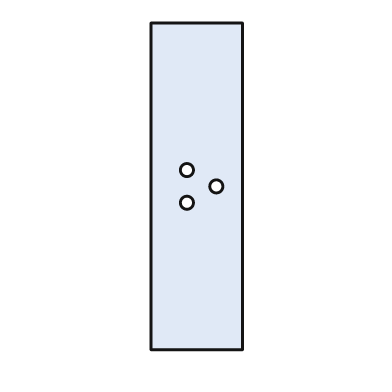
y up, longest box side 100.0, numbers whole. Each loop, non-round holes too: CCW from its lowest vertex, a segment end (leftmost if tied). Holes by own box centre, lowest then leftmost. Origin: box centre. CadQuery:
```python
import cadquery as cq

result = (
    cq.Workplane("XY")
    .moveTo(-14.0, -50.0)
    .lineTo(14.0, -50.0)
    .lineTo(14.0, 50.0)
    .lineTo(-14.0, 50.0)
    .close()
    .moveTo(-3.0, -5.0)
    .circle(2.0)
    .moveTo(6.0, 0.0)
    .circle(2.0)
    .moveTo(-3.0, 5.0)
    .circle(2.0)
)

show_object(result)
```